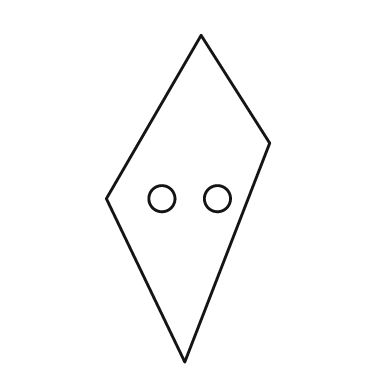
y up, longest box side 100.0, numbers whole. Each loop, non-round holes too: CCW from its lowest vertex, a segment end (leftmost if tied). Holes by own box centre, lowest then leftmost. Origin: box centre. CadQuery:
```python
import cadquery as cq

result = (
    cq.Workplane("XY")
    .moveTo(-1.0, -50.0)
    .lineTo(25.0, 17.0)
    .lineTo(4.0, 50.0)
    .lineTo(-25.0, 0.0)
    .close()
    .moveTo(-8.0, 0.0)
    .circle(4.0)
    .moveTo(9.0, 0.0)
    .circle(4.0)
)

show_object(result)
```